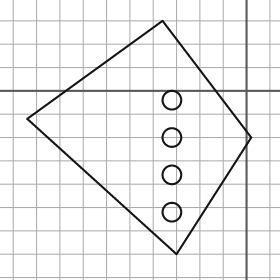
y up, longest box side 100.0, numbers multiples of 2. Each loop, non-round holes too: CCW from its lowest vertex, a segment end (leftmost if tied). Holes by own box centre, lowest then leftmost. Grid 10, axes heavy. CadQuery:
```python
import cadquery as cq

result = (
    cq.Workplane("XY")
    .moveTo(-30.0, -70.0)
    .lineTo(2.0, -20.0)
    .lineTo(-36.0, 30.0)
    .lineTo(-94.0, -12.0)
    .close()
    .moveTo(-32.0, -52.0)
    .circle(4.0)
    .moveTo(-32.0, -36.0)
    .circle(4.0)
    .moveTo(-32.0, -20.0)
    .circle(4.0)
    .moveTo(-32.0, -4.0)
    .circle(4.0)
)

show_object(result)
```